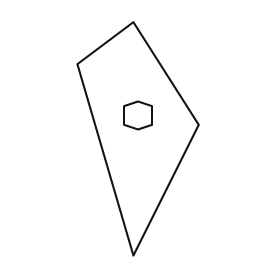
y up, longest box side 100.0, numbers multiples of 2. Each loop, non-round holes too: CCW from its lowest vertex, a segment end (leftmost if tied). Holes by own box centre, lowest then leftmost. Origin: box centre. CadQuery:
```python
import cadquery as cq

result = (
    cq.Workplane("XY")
    .moveTo(-2.0, -50.0)
    .lineTo(26.0, 6.0)
    .lineTo(-2.0, 50.0)
    .lineTo(-26.0, 32.0)
    .close()
    .moveTo(0.0, 4.0)
    .lineTo(6.0, 6.0)
    .lineTo(6.0, 14.0)
    .lineTo(0.0, 16.0)
    .lineTo(-6.0, 14.0)
    .lineTo(-6.0, 6.0)
    .close()
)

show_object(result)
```